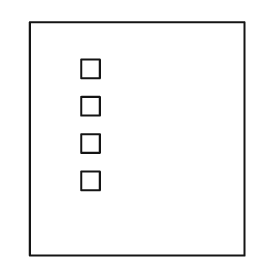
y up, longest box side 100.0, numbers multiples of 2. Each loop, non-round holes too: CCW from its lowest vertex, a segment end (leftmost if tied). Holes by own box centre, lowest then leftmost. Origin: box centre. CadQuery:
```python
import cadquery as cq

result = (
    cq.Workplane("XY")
    .moveTo(-46.0, -50.0)
    .lineTo(46.0, -50.0)
    .lineTo(46.0, 50.0)
    .lineTo(-46.0, 50.0)
    .close()
    .moveTo(-24.0, -22.0)
    .lineTo(-16.0, -22.0)
    .lineTo(-16.0, -14.0)
    .lineTo(-24.0, -14.0)
    .close()
    .moveTo(-24.0, -6.0)
    .lineTo(-16.0, -6.0)
    .lineTo(-16.0, 2.0)
    .lineTo(-24.0, 2.0)
    .close()
    .moveTo(-24.0, 10.0)
    .lineTo(-16.0, 10.0)
    .lineTo(-16.0, 18.0)
    .lineTo(-24.0, 18.0)
    .close()
    .moveTo(-24.0, 26.0)
    .lineTo(-16.0, 26.0)
    .lineTo(-16.0, 34.0)
    .lineTo(-24.0, 34.0)
    .close()
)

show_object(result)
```